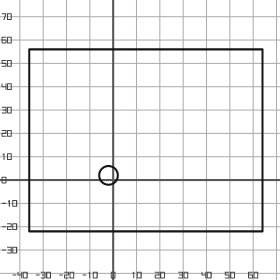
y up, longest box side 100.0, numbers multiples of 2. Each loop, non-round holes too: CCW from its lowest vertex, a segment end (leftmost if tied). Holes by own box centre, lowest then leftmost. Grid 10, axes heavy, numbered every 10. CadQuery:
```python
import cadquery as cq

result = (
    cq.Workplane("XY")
    .moveTo(-36.0, -22.0)
    .lineTo(64.0, -22.0)
    .lineTo(64.0, 56.0)
    .lineTo(-36.0, 56.0)
    .close()
    .moveTo(-2.0, 2.0)
    .circle(4.0)
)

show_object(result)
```